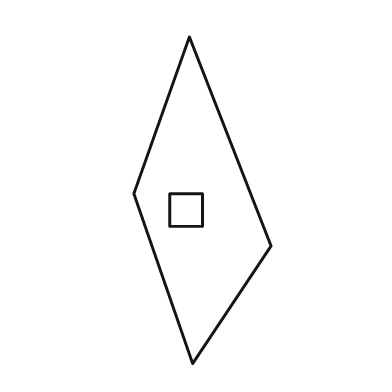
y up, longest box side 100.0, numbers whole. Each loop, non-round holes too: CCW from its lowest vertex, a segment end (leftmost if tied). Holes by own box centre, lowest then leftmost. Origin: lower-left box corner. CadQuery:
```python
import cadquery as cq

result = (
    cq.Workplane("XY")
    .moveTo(18.0, 0.0)
    .lineTo(42.0, 36.0)
    .lineTo(17.0, 100.0)
    .lineTo(0.0, 52.0)
    .close()
    .moveTo(11.0, 42.0)
    .lineTo(21.0, 42.0)
    .lineTo(21.0, 52.0)
    .lineTo(11.0, 52.0)
    .close()
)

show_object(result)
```